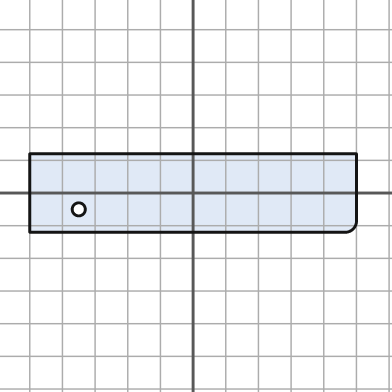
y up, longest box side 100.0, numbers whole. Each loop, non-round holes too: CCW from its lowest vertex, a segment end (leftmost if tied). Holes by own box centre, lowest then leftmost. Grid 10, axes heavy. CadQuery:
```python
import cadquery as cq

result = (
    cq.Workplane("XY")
    .moveTo(-50.0, -12.0)
    .lineTo(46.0, -12.0)
    .threePointArc((49.0, -11.0), (50.0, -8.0))
    .lineTo(50.0, 12.0)
    .lineTo(-50.0, 12.0)
    .close()
    .moveTo(-35.0, -5.0)
    .circle(2.0)
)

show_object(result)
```